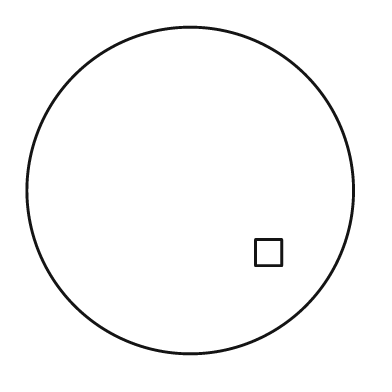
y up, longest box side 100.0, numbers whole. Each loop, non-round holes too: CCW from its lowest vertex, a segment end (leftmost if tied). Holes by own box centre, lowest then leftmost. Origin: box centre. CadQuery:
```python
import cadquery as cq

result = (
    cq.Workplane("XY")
    .moveTo(0.0, 0.0)
    .circle(50.0)
    .moveTo(20.0, -23.0)
    .lineTo(28.0, -23.0)
    .lineTo(28.0, -15.0)
    .lineTo(20.0, -15.0)
    .close()
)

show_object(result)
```